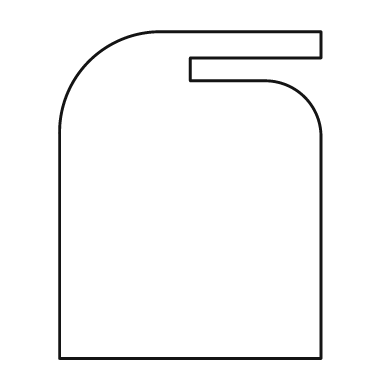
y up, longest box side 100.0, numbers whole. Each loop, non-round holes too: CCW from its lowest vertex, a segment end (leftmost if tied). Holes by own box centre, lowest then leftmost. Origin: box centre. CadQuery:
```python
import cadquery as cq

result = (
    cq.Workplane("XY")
    .moveTo(-40.0, -50.0)
    .lineTo(40.0, -50.0)
    .lineTo(40.0, 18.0)
    .threePointArc((35.0, 30.0), (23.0, 35.0))
    .lineTo(0.0, 35.0)
    .lineTo(0.0, 42.0)
    .lineTo(40.0, 42.0)
    .lineTo(40.0, 50.0)
    .lineTo(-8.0, 50.0)
    .threePointArc((-31.0, 41.0), (-40.0, 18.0))
    .close()
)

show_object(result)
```